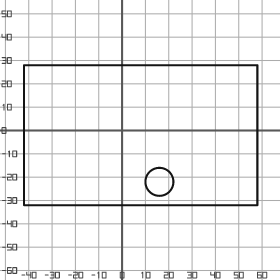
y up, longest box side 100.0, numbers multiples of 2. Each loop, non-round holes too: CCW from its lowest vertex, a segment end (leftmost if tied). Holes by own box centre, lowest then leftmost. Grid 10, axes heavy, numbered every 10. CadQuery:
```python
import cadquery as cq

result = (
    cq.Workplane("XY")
    .moveTo(-42.0, -32.0)
    .lineTo(58.0, -32.0)
    .lineTo(58.0, 28.0)
    .lineTo(-42.0, 28.0)
    .close()
    .moveTo(16.0, -22.0)
    .circle(6.0)
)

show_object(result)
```